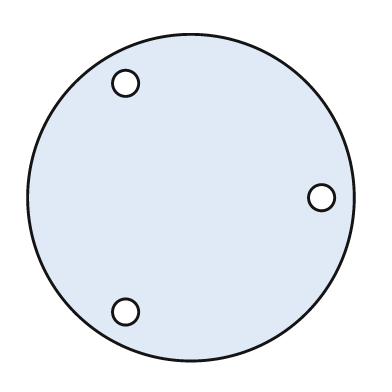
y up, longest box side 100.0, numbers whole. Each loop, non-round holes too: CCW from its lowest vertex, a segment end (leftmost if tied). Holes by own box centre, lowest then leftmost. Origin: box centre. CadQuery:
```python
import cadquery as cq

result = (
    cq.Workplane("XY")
    .moveTo(0.0, 0.0)
    .circle(50.0)
    .moveTo(-20.0, -35.0)
    .circle(4.0)
    .moveTo(40.0, 0.0)
    .circle(4.0)
    .moveTo(-20.0, 35.0)
    .circle(4.0)
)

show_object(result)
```